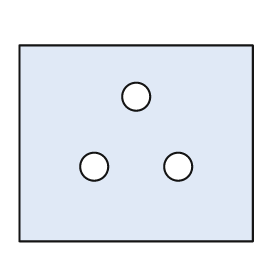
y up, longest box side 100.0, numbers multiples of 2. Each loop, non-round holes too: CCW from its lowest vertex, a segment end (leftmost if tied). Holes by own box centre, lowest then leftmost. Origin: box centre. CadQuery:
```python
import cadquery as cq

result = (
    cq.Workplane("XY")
    .moveTo(-50.0, -42.0)
    .lineTo(50.0, -42.0)
    .lineTo(50.0, 42.0)
    .lineTo(-50.0, 42.0)
    .close()
    .moveTo(-18.0, -10.0)
    .circle(6.0)
    .moveTo(18.0, -10.0)
    .circle(6.0)
    .moveTo(0.0, 20.0)
    .circle(6.0)
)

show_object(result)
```